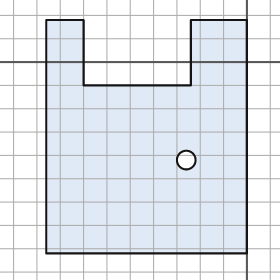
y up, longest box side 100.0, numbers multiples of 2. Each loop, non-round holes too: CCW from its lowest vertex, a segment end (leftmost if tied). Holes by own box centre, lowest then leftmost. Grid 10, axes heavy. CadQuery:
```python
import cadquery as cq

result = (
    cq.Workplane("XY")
    .moveTo(-86.0, -82.0)
    .lineTo(0.0, -82.0)
    .lineTo(0.0, 18.0)
    .lineTo(-24.0, 18.0)
    .lineTo(-24.0, -10.0)
    .lineTo(-70.0, -10.0)
    .lineTo(-70.0, 18.0)
    .lineTo(-86.0, 18.0)
    .close()
    .moveTo(-26.0, -42.0)
    .circle(4.0)
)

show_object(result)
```